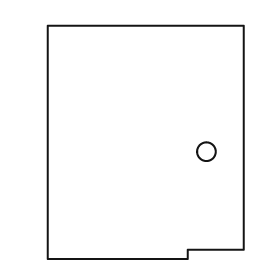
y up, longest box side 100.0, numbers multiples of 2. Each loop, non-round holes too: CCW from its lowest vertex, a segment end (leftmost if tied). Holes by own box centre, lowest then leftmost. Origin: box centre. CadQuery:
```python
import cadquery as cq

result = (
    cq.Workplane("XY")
    .moveTo(-42.0, -50.0)
    .lineTo(18.0, -50.0)
    .lineTo(18.0, -46.0)
    .lineTo(42.0, -46.0)
    .lineTo(42.0, 50.0)
    .lineTo(-42.0, 50.0)
    .close()
    .moveTo(26.0, -4.0)
    .circle(4.0)
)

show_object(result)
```